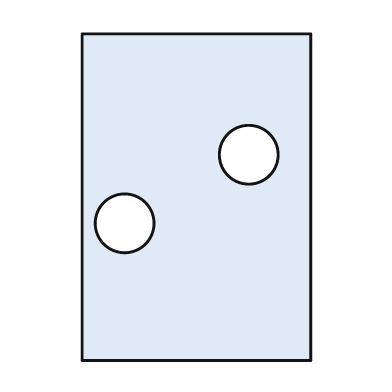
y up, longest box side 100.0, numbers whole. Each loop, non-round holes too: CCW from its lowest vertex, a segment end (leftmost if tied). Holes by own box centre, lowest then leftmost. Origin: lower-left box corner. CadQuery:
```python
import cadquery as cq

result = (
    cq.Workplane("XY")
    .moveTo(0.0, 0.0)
    .lineTo(70.0, 0.0)
    .lineTo(70.0, 100.0)
    .lineTo(0.0, 100.0)
    .close()
    .moveTo(13.0, 42.0)
    .circle(9.0)
    .moveTo(51.0, 63.0)
    .circle(9.0)
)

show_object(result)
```